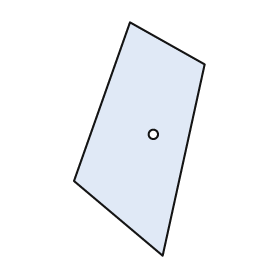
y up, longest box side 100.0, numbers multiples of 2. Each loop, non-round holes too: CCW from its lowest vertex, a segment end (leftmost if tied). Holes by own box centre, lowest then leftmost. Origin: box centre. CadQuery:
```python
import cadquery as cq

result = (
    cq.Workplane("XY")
    .moveTo(10.0, -50.0)
    .lineTo(28.0, 32.0)
    .lineTo(-4.0, 50.0)
    .lineTo(-28.0, -18.0)
    .close()
    .moveTo(6.0, 2.0)
    .circle(2.0)
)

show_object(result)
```